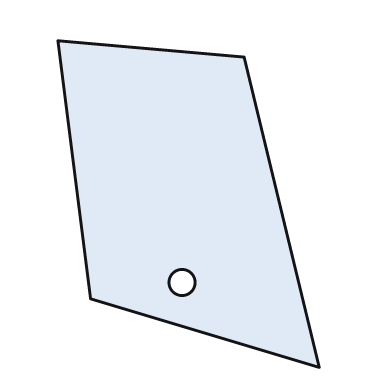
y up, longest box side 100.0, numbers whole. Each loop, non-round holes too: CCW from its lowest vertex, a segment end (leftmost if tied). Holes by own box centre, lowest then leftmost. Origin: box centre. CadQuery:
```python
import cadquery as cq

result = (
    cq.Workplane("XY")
    .moveTo(40.0, -50.0)
    .lineTo(17.0, 45.0)
    .lineTo(-40.0, 50.0)
    .lineTo(-30.0, -29.0)
    .close()
    .moveTo(-2.0, -24.0)
    .circle(4.0)
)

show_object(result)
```